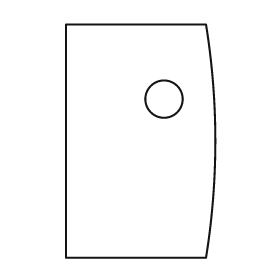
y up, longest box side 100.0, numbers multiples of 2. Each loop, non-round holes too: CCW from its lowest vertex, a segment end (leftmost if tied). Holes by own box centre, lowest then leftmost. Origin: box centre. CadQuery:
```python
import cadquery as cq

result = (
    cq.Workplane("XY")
    .moveTo(-32.0, -50.0)
    .lineTo(28.0, -50.0)
    .threePointArc((32.0, 0.0), (28.0, 50.0))
    .lineTo(-32.0, 50.0)
    .close()
    .moveTo(10.0, 18.0)
    .circle(8.0)
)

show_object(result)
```